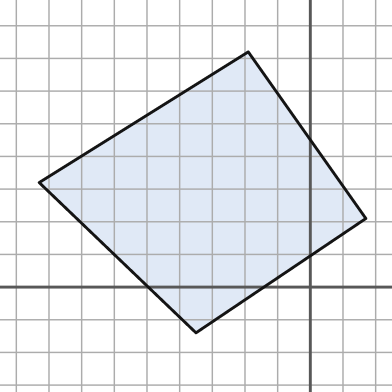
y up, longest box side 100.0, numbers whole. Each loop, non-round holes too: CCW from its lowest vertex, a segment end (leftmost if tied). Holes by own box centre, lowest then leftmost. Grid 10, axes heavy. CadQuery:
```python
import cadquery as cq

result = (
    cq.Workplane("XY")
    .moveTo(-35.0, -14.0)
    .lineTo(17.0, 21.0)
    .lineTo(-19.0, 72.0)
    .lineTo(-83.0, 32.0)
    .close()
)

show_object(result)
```